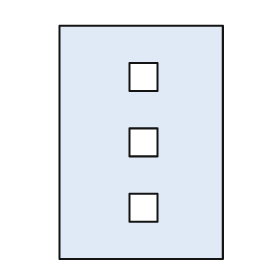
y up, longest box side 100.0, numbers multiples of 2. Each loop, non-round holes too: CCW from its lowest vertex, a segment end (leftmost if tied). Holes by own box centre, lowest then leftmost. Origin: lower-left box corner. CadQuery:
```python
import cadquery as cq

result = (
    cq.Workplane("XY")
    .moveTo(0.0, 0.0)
    .lineTo(70.0, 0.0)
    .lineTo(70.0, 100.0)
    .lineTo(0.0, 100.0)
    .close()
    .moveTo(30.0, 16.0)
    .lineTo(42.0, 16.0)
    .lineTo(42.0, 28.0)
    .lineTo(30.0, 28.0)
    .close()
    .moveTo(30.0, 44.0)
    .lineTo(42.0, 44.0)
    .lineTo(42.0, 56.0)
    .lineTo(30.0, 56.0)
    .close()
    .moveTo(30.0, 72.0)
    .lineTo(42.0, 72.0)
    .lineTo(42.0, 84.0)
    .lineTo(30.0, 84.0)
    .close()
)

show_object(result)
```